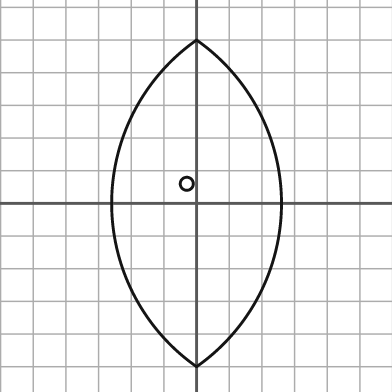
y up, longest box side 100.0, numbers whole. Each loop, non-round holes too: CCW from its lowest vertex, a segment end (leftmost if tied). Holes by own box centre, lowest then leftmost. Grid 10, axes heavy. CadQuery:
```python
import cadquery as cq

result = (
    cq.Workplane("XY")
    .moveTo(0.0, -50.0)
    .threePointArc((26.0, 0.0), (0.0, 50.0))
    .threePointArc((-26.0, 0.0), (0.0, -50.0))
    .close()
    .moveTo(-3.0, 6.0)
    .circle(2.0)
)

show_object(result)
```